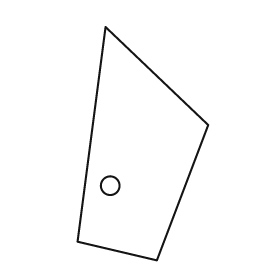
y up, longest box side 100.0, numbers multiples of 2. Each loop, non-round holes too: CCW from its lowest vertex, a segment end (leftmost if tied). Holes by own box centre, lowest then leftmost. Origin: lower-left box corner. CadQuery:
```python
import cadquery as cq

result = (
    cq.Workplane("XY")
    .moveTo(34.0, 0.0)
    .lineTo(56.0, 58.0)
    .lineTo(12.0, 100.0)
    .lineTo(0.0, 8.0)
    .close()
    .moveTo(14.0, 32.0)
    .circle(4.0)
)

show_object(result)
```